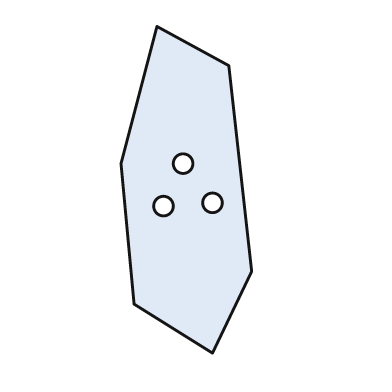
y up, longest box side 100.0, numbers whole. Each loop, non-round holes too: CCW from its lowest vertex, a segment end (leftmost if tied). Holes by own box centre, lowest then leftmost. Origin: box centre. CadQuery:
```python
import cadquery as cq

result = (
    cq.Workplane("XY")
    .moveTo(8.0, -50.0)
    .lineTo(20.0, -25.0)
    .lineTo(13.0, 38.0)
    .lineTo(-9.0, 50.0)
    .lineTo(-20.0, 8.0)
    .lineTo(-16.0, -35.0)
    .close()
    .moveTo(-7.0, -5.0)
    .circle(3.0)
    .moveTo(8.0, -4.0)
    .circle(3.0)
    .moveTo(-1.0, 8.0)
    .circle(3.0)
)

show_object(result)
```